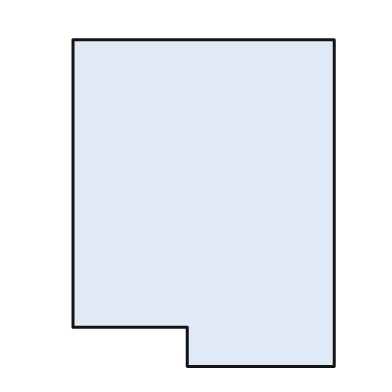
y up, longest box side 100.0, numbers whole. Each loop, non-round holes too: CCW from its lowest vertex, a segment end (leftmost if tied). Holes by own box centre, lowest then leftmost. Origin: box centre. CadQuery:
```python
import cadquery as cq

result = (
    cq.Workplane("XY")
    .moveTo(-5.0, -50.0)
    .lineTo(40.0, -50.0)
    .lineTo(40.0, 50.0)
    .lineTo(-40.0, 50.0)
    .lineTo(-40.0, -38.0)
    .lineTo(-5.0, -38.0)
    .close()
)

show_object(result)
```